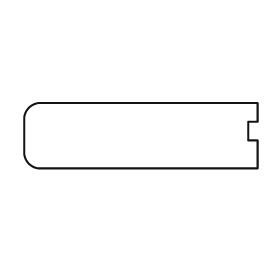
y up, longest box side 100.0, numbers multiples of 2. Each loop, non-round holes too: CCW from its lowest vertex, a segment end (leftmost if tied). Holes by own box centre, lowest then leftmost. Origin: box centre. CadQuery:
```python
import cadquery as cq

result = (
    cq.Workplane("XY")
    .moveTo(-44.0, -14.0)
    .lineTo(50.0, -14.0)
    .lineTo(50.0, -2.0)
    .lineTo(46.0, -2.0)
    .lineTo(46.0, 6.0)
    .lineTo(50.0, 6.0)
    .lineTo(50.0, 14.0)
    .lineTo(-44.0, 14.0)
    .threePointArc((-48.0, 12.0), (-50.0, 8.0))
    .lineTo(-50.0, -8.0)
    .threePointArc((-48.0, -12.0), (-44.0, -14.0))
    .close()
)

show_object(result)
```